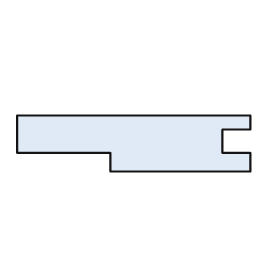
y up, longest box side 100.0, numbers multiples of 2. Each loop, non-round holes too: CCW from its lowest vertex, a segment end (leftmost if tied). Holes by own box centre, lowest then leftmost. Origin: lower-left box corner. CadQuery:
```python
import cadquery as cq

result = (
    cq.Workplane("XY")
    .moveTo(40.0, 0.0)
    .lineTo(100.0, 0.0)
    .lineTo(100.0, 8.0)
    .lineTo(88.0, 8.0)
    .lineTo(88.0, 18.0)
    .lineTo(100.0, 18.0)
    .lineTo(100.0, 24.0)
    .lineTo(0.0, 24.0)
    .lineTo(0.0, 8.0)
    .lineTo(40.0, 8.0)
    .close()
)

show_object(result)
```